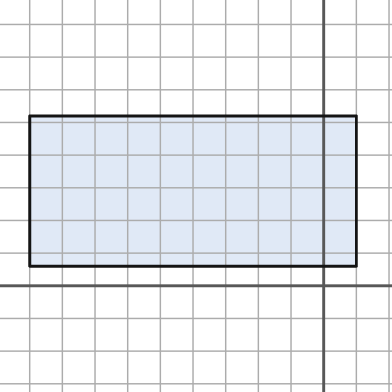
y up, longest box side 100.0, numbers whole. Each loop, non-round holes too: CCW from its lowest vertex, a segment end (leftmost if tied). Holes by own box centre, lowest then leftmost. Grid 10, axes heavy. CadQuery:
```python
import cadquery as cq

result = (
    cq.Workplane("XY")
    .moveTo(-90.0, 6.0)
    .lineTo(10.0, 6.0)
    .lineTo(10.0, 52.0)
    .lineTo(-90.0, 52.0)
    .close()
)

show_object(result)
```